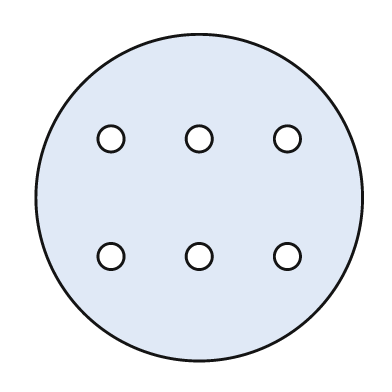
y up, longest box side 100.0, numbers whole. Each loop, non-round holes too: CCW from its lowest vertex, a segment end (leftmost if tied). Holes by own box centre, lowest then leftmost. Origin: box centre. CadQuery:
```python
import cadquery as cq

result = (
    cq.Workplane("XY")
    .moveTo(0.0, 0.0)
    .circle(50.0)
    .moveTo(-27.0, -18.0)
    .circle(4.0)
    .moveTo(0.0, -18.0)
    .circle(4.0)
    .moveTo(27.0, -18.0)
    .circle(4.0)
    .moveTo(-27.0, 18.0)
    .circle(4.0)
    .moveTo(0.0, 18.0)
    .circle(4.0)
    .moveTo(27.0, 18.0)
    .circle(4.0)
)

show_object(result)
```